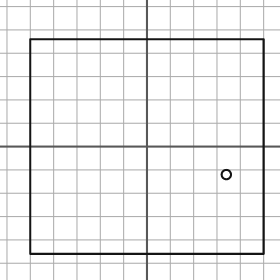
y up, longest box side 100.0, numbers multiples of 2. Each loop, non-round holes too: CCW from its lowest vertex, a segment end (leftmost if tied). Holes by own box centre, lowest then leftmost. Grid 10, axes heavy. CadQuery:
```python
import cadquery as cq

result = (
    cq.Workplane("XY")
    .moveTo(-50.0, -46.0)
    .lineTo(50.0, -46.0)
    .lineTo(50.0, 46.0)
    .lineTo(-50.0, 46.0)
    .close()
    .moveTo(34.0, -12.0)
    .circle(2.0)
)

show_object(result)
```